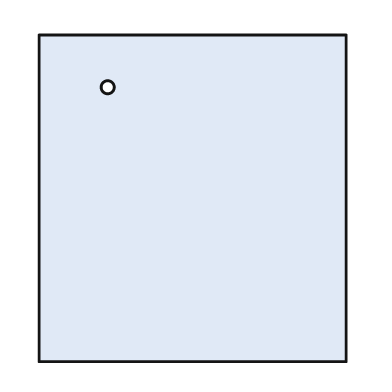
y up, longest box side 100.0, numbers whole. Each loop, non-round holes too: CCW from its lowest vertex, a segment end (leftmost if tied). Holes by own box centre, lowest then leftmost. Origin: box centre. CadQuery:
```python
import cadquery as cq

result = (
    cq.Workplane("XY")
    .moveTo(-47.0, -50.0)
    .lineTo(47.0, -50.0)
    .lineTo(47.0, 50.0)
    .lineTo(-47.0, 50.0)
    .close()
    .moveTo(-26.0, 34.0)
    .circle(2.0)
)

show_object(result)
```